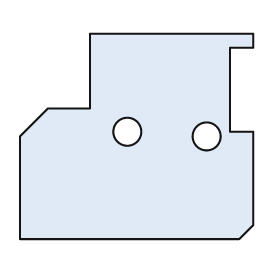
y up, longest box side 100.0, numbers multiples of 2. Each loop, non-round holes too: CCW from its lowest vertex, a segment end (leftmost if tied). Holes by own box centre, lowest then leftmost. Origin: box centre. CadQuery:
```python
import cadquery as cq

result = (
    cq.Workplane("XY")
    .moveTo(-50.0, -44.0)
    .lineTo(44.0, -44.0)
    .lineTo(50.0, -38.0)
    .lineTo(50.0, 2.0)
    .lineTo(40.0, 2.0)
    .lineTo(40.0, 38.0)
    .lineTo(50.0, 38.0)
    .lineTo(50.0, 44.0)
    .lineTo(-20.0, 44.0)
    .lineTo(-20.0, 12.0)
    .lineTo(-38.0, 12.0)
    .lineTo(-50.0, 0.0)
    .close()
    .moveTo(30.0, 0.0)
    .circle(6.0)
    .moveTo(-4.0, 2.0)
    .circle(6.0)
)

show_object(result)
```